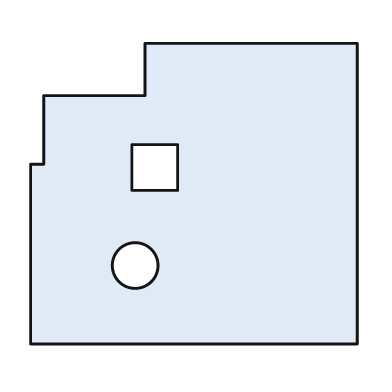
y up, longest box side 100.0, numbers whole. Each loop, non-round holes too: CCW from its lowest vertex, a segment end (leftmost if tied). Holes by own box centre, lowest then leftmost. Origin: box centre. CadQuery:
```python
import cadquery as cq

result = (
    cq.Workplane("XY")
    .moveTo(-50.0, -46.0)
    .lineTo(50.0, -46.0)
    .lineTo(50.0, 46.0)
    .lineTo(-15.0, 46.0)
    .lineTo(-15.0, 30.0)
    .lineTo(-46.0, 30.0)
    .lineTo(-46.0, 9.0)
    .lineTo(-50.0, 9.0)
    .close()
    .moveTo(-18.0, -22.0)
    .circle(7.0)
    .moveTo(-19.0, 1.0)
    .lineTo(-5.0, 1.0)
    .lineTo(-5.0, 15.0)
    .lineTo(-19.0, 15.0)
    .close()
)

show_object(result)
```